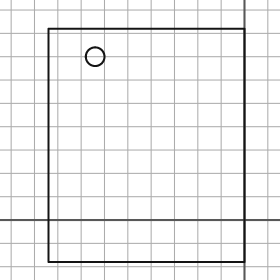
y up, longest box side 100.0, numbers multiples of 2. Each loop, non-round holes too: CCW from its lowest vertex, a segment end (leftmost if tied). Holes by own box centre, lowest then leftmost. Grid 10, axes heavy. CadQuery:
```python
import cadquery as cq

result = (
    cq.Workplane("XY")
    .moveTo(-84.0, -18.0)
    .lineTo(0.0, -18.0)
    .lineTo(0.0, 82.0)
    .lineTo(-84.0, 82.0)
    .close()
    .moveTo(-64.0, 70.0)
    .circle(4.0)
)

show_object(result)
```